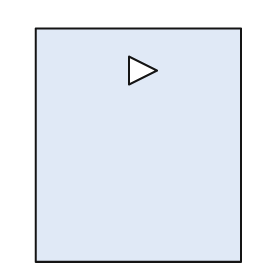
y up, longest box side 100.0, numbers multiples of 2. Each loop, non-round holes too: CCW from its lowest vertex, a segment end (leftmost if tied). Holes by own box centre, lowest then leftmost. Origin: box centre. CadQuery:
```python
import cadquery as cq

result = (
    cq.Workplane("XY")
    .moveTo(-44.0, -50.0)
    .lineTo(44.0, -50.0)
    .lineTo(44.0, 50.0)
    .lineTo(-44.0, 50.0)
    .close()
    .moveTo(-4.0, 26.0)
    .lineTo(8.0, 32.0)
    .lineTo(-4.0, 38.0)
    .close()
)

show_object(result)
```